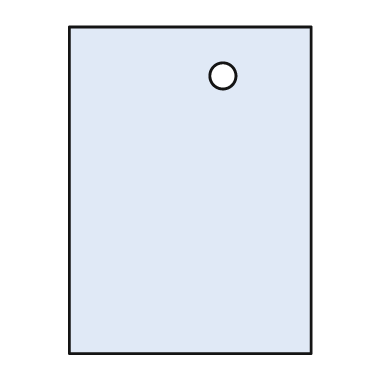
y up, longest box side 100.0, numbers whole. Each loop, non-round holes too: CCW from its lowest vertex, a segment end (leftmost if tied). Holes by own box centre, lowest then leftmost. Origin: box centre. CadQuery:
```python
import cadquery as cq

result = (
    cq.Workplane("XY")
    .moveTo(-37.0, -50.0)
    .lineTo(37.0, -50.0)
    .lineTo(37.0, 50.0)
    .lineTo(-37.0, 50.0)
    .close()
    .moveTo(10.0, 35.0)
    .circle(4.0)
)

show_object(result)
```